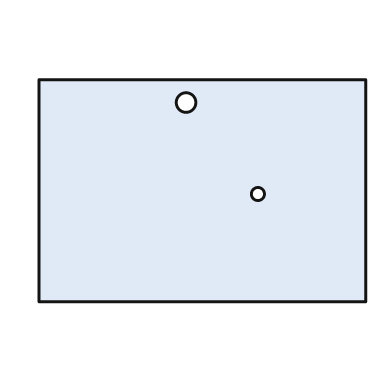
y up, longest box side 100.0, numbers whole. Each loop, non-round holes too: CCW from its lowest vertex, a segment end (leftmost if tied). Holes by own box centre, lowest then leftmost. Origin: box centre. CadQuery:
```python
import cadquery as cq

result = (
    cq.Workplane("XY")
    .moveTo(-50.0, -34.0)
    .lineTo(50.0, -34.0)
    .lineTo(50.0, 34.0)
    .lineTo(-50.0, 34.0)
    .close()
    .moveTo(17.0, -1.0)
    .circle(2.0)
    .moveTo(-5.0, 27.0)
    .circle(3.0)
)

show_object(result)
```